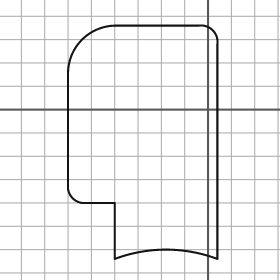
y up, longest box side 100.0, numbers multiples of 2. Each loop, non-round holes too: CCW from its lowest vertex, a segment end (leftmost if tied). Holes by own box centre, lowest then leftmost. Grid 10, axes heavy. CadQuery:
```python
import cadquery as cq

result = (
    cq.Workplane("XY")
    .moveTo(-40.0, -64.0)
    .threePointArc((-18.0, -60.0), (4.0, -64.0))
    .lineTo(4.0, 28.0)
    .threePointArc((2.0, 34.0), (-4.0, 36.0))
    .lineTo(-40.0, 36.0)
    .threePointArc((-54.0, 30.0), (-60.0, 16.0))
    .lineTo(-60.0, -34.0)
    .threePointArc((-58.0, -38.0), (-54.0, -40.0))
    .lineTo(-40.0, -40.0)
    .close()
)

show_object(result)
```